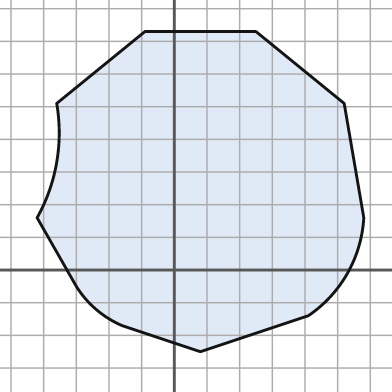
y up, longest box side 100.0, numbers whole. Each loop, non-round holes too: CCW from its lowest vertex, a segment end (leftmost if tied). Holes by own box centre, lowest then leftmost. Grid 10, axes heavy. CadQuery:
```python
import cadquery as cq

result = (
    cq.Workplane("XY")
    .moveTo(8.0, -25.0)
    .lineTo(41.0, -14.0)
    .threePointArc((53.0, -1.0), (58.0, 16.0))
    .lineTo(52.0, 51.0)
    .lineTo(25.0, 73.0)
    .lineTo(-9.0, 73.0)
    .lineTo(-36.0, 51.0)
    .threePointArc((-36.0, 33.0), (-42.0, 16.0))
    .lineTo(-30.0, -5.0)
    .threePointArc((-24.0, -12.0), (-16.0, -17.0))
    .close()
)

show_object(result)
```